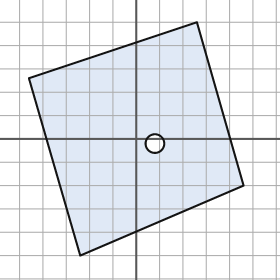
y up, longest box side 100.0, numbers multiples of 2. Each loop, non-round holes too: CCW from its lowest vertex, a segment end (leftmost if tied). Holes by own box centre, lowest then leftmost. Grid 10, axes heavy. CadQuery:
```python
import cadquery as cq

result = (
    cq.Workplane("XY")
    .moveTo(-24.0, -50.0)
    .lineTo(46.0, -20.0)
    .lineTo(26.0, 50.0)
    .lineTo(-46.0, 26.0)
    .close()
    .moveTo(8.0, -2.0)
    .circle(4.0)
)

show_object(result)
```